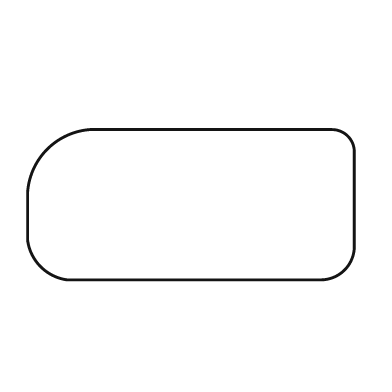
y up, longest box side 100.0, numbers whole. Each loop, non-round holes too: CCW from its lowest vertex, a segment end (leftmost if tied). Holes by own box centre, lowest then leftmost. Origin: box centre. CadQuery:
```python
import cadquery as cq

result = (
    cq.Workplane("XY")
    .moveTo(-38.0, -23.0)
    .lineTo(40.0, -23.0)
    .threePointArc((47.0, -20.0), (50.0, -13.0))
    .lineTo(50.0, 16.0)
    .threePointArc((48.0, 21.0), (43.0, 23.0))
    .lineTo(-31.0, 23.0)
    .threePointArc((-44.0, 17.0), (-50.0, 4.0))
    .lineTo(-50.0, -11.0)
    .threePointArc((-46.0, -19.0), (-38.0, -23.0))
    .close()
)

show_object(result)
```